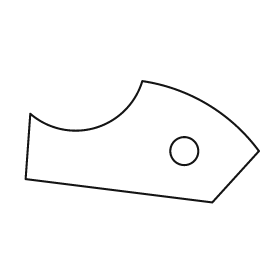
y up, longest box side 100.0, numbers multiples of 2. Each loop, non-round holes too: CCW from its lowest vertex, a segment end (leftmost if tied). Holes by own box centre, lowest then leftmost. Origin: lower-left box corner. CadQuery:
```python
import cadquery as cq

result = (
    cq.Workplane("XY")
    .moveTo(80.0, 0.0)
    .lineTo(100.0, 22.0)
    .threePointArc((78.0, 42.0), (50.0, 52.0))
    .threePointArc((30.0, 32.0), (2.0, 38.0))
    .lineTo(0.0, 10.0)
    .close()
    .moveTo(68.0, 22.0)
    .circle(6.0)
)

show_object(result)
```